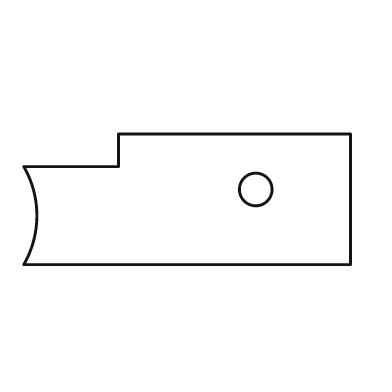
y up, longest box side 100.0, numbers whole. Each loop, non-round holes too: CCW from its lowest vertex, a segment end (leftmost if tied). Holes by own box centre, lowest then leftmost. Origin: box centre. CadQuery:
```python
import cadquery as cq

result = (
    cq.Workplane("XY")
    .moveTo(-50.0, -20.0)
    .lineTo(50.0, -20.0)
    .lineTo(50.0, 20.0)
    .lineTo(-21.0, 20.0)
    .lineTo(-21.0, 10.0)
    .lineTo(-50.0, 10.0)
    .threePointArc((-46.0, -5.0), (-50.0, -20.0))
    .close()
    .moveTo(21.0, 3.0)
    .circle(5.0)
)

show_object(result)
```